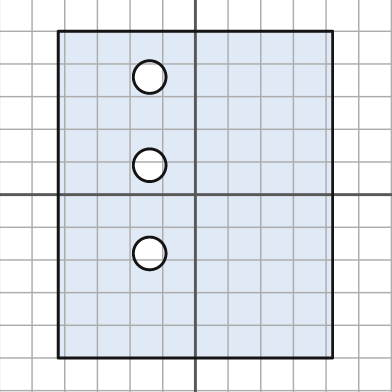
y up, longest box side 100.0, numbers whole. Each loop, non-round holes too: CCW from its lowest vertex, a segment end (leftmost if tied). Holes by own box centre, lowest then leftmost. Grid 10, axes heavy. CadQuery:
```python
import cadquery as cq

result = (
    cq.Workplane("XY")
    .moveTo(-42.0, -50.0)
    .lineTo(42.0, -50.0)
    .lineTo(42.0, 50.0)
    .lineTo(-42.0, 50.0)
    .close()
    .moveTo(-14.0, -18.0)
    .circle(5.0)
    .moveTo(-14.0, 9.0)
    .circle(5.0)
    .moveTo(-14.0, 36.0)
    .circle(5.0)
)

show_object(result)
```